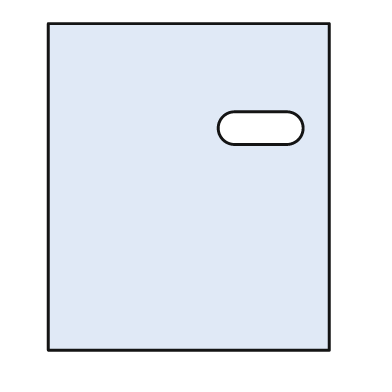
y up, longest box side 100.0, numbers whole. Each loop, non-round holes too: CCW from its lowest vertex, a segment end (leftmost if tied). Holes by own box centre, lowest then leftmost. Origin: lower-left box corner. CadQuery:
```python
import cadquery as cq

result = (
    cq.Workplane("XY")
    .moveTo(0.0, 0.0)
    .lineTo(86.0, 0.0)
    .lineTo(86.0, 100.0)
    .lineTo(0.0, 100.0)
    .close()
    .moveTo(57.0, 63.0)
    .lineTo(73.0, 63.0)
    .threePointArc((78.0, 68.0), (73.0, 73.0))
    .lineTo(57.0, 73.0)
    .threePointArc((52.0, 68.0), (57.0, 63.0))
    .close()
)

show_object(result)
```